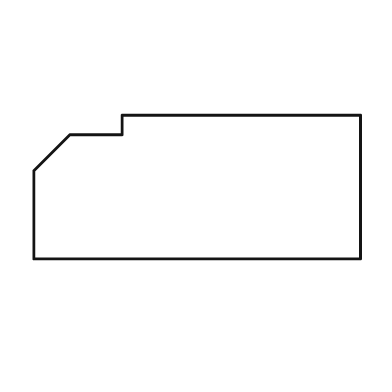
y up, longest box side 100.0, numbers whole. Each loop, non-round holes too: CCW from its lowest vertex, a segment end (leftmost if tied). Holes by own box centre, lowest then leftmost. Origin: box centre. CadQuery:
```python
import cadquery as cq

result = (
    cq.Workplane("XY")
    .moveTo(-50.0, -22.0)
    .lineTo(50.0, -22.0)
    .lineTo(50.0, 22.0)
    .lineTo(-23.0, 22.0)
    .lineTo(-23.0, 16.0)
    .lineTo(-39.0, 16.0)
    .lineTo(-50.0, 5.0)
    .close()
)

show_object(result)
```